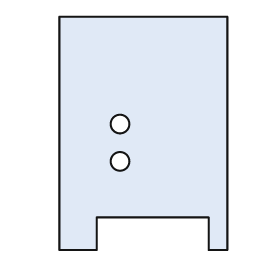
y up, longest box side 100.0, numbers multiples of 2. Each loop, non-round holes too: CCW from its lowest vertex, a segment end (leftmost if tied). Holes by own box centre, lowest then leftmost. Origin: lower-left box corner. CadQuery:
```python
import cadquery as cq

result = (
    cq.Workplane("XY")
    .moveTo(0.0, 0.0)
    .lineTo(16.0, 0.0)
    .lineTo(16.0, 14.0)
    .lineTo(64.0, 14.0)
    .lineTo(64.0, 0.0)
    .lineTo(72.0, 0.0)
    .lineTo(72.0, 100.0)
    .lineTo(0.0, 100.0)
    .close()
    .moveTo(26.0, 38.0)
    .circle(4.0)
    .moveTo(26.0, 54.0)
    .circle(4.0)
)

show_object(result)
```